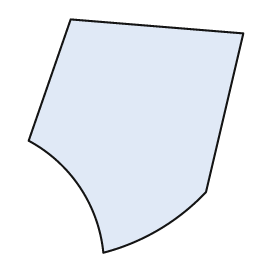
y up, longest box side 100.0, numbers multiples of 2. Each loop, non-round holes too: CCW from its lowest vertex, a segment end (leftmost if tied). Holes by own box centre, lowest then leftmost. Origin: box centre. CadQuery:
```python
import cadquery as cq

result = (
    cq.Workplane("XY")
    .moveTo(-14.0, -50.0)
    .threePointArc((10.0, -40.0), (30.0, -24.0))
    .lineTo(46.0, 44.0)
    .lineTo(-28.0, 50.0)
    .lineTo(-46.0, -2.0)
    .threePointArc((-24.0, -22.0), (-14.0, -50.0))
    .close()
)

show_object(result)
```